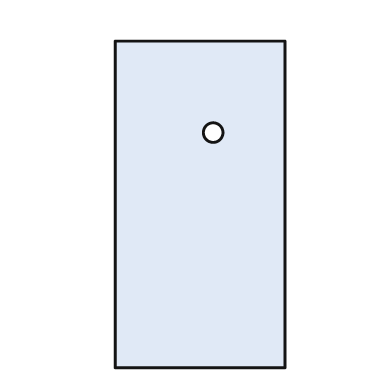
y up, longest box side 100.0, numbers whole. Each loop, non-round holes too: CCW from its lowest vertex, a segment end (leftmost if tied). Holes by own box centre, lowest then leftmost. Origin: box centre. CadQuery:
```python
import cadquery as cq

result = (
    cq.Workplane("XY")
    .moveTo(-26.0, -50.0)
    .lineTo(26.0, -50.0)
    .lineTo(26.0, 50.0)
    .lineTo(-26.0, 50.0)
    .close()
    .moveTo(4.0, 22.0)
    .circle(3.0)
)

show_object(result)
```